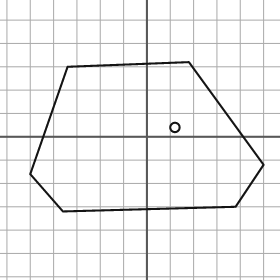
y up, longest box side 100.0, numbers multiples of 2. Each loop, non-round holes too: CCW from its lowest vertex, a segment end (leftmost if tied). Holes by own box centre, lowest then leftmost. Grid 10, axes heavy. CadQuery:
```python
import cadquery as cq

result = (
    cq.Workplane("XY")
    .moveTo(-36.0, -32.0)
    .lineTo(38.0, -30.0)
    .lineTo(50.0, -12.0)
    .lineTo(18.0, 32.0)
    .lineTo(-34.0, 30.0)
    .lineTo(-50.0, -16.0)
    .close()
    .moveTo(12.0, 4.0)
    .circle(2.0)
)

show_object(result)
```